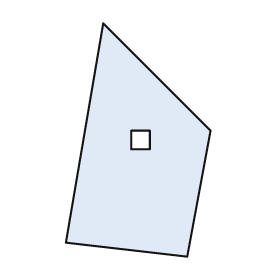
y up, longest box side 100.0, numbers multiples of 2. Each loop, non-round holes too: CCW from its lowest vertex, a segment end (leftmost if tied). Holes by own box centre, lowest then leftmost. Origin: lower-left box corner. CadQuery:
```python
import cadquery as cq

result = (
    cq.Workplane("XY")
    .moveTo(52.0, 0.0)
    .lineTo(62.0, 54.0)
    .lineTo(16.0, 100.0)
    .lineTo(0.0, 6.0)
    .close()
    .moveTo(28.0, 46.0)
    .lineTo(36.0, 46.0)
    .lineTo(36.0, 54.0)
    .lineTo(28.0, 54.0)
    .close()
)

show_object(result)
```